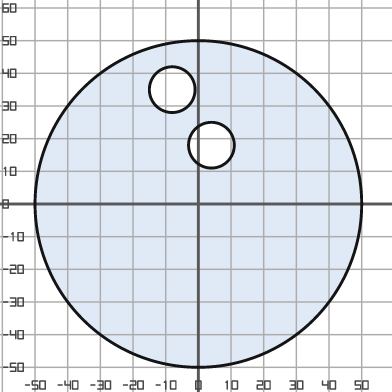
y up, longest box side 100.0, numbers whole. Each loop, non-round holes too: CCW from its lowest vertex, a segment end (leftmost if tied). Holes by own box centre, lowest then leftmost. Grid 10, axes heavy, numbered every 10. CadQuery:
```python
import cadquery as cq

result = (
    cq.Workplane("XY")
    .moveTo(0.0, 0.0)
    .circle(50.0)
    .moveTo(4.0, 18.0)
    .circle(7.0)
    .moveTo(-8.0, 35.0)
    .circle(7.0)
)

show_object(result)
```